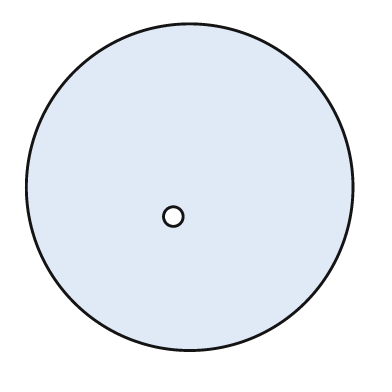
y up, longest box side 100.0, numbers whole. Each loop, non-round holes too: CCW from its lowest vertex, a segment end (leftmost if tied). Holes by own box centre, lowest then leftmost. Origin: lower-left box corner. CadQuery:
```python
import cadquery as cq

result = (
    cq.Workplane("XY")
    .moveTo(50.0, 50.0)
    .circle(50.0)
    .moveTo(45.0, 41.0)
    .circle(3.0)
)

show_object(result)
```